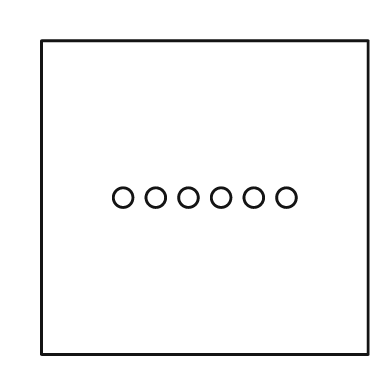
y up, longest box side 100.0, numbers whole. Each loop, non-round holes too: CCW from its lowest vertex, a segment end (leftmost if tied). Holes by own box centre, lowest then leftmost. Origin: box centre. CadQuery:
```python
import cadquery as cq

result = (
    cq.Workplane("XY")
    .moveTo(-50.0, -48.0)
    .lineTo(50.0, -48.0)
    .lineTo(50.0, 48.0)
    .lineTo(-50.0, 48.0)
    .close()
    .moveTo(-25.0, 0.0)
    .circle(3.0)
    .moveTo(-15.0, 0.0)
    .circle(3.0)
    .moveTo(-5.0, 0.0)
    .circle(3.0)
    .moveTo(5.0, 0.0)
    .circle(3.0)
    .moveTo(15.0, 0.0)
    .circle(3.0)
    .moveTo(25.0, 0.0)
    .circle(3.0)
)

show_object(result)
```